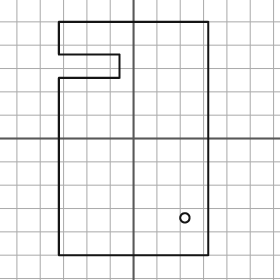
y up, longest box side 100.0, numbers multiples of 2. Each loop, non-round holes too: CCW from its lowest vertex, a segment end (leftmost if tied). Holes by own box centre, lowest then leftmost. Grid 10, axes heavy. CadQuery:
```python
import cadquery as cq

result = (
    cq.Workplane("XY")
    .moveTo(-32.0, -50.0)
    .lineTo(32.0, -50.0)
    .lineTo(32.0, 50.0)
    .lineTo(-32.0, 50.0)
    .lineTo(-32.0, 36.0)
    .lineTo(-6.0, 36.0)
    .lineTo(-6.0, 26.0)
    .lineTo(-32.0, 26.0)
    .close()
    .moveTo(22.0, -34.0)
    .circle(2.0)
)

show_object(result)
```